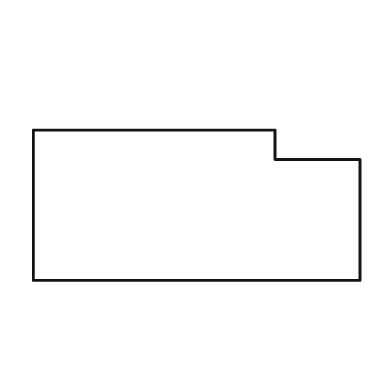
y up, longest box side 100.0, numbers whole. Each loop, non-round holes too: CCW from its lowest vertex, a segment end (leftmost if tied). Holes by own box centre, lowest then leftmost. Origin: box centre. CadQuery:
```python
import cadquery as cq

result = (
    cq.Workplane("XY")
    .moveTo(-50.0, -23.0)
    .lineTo(50.0, -23.0)
    .lineTo(50.0, 14.0)
    .lineTo(24.0, 14.0)
    .lineTo(24.0, 23.0)
    .lineTo(-50.0, 23.0)
    .close()
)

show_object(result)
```